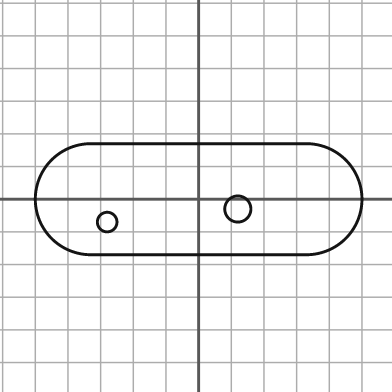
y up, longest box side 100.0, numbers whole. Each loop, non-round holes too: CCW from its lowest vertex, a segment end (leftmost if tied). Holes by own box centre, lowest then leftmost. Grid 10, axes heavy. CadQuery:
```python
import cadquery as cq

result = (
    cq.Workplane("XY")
    .moveTo(-33.0, -17.0)
    .lineTo(33.0, -17.0)
    .threePointArc((50.0, 0.0), (33.0, 17.0))
    .lineTo(-33.0, 17.0)
    .threePointArc((-50.0, 0.0), (-33.0, -17.0))
    .close()
    .moveTo(-28.0, -7.0)
    .circle(3.0)
    .moveTo(12.0, -3.0)
    .circle(4.0)
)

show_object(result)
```